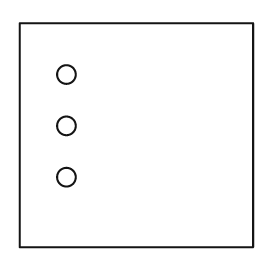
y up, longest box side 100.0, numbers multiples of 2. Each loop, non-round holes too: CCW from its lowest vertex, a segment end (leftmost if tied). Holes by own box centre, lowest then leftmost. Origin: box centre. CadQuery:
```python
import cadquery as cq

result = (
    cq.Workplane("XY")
    .moveTo(-50.0, -48.0)
    .lineTo(50.0, -48.0)
    .lineTo(50.0, 48.0)
    .lineTo(-50.0, 48.0)
    .close()
    .moveTo(-30.0, -18.0)
    .circle(4.0)
    .moveTo(-30.0, 4.0)
    .circle(4.0)
    .moveTo(-30.0, 26.0)
    .circle(4.0)
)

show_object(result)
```